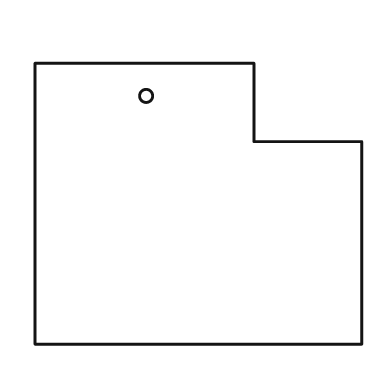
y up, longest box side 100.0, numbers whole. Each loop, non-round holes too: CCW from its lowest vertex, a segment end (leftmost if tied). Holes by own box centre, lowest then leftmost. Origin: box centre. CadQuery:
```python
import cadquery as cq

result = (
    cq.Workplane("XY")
    .moveTo(-50.0, -43.0)
    .lineTo(50.0, -43.0)
    .lineTo(50.0, 19.0)
    .lineTo(17.0, 19.0)
    .lineTo(17.0, 43.0)
    .lineTo(-50.0, 43.0)
    .close()
    .moveTo(-16.0, 33.0)
    .circle(2.0)
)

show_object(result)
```